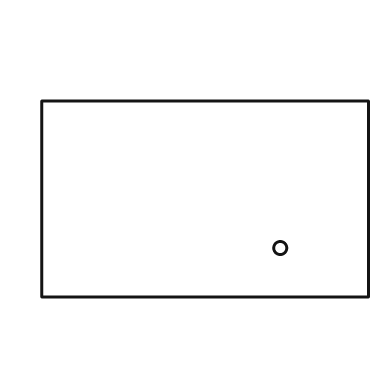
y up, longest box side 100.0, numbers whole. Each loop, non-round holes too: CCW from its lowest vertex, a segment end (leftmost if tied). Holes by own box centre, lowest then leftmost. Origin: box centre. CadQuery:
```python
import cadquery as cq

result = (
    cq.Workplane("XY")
    .moveTo(-50.0, -30.0)
    .lineTo(50.0, -30.0)
    .lineTo(50.0, 30.0)
    .lineTo(-50.0, 30.0)
    .close()
    .moveTo(23.0, -15.0)
    .circle(2.0)
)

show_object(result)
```